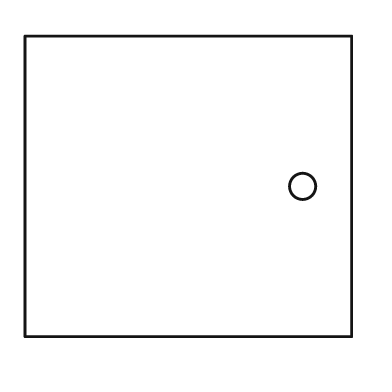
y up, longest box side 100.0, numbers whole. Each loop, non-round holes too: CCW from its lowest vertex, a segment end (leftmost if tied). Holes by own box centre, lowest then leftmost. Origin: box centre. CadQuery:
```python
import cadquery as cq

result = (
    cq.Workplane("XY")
    .moveTo(-50.0, -46.0)
    .lineTo(50.0, -46.0)
    .lineTo(50.0, 46.0)
    .lineTo(-50.0, 46.0)
    .close()
    .moveTo(35.0, 0.0)
    .circle(4.0)
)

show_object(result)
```